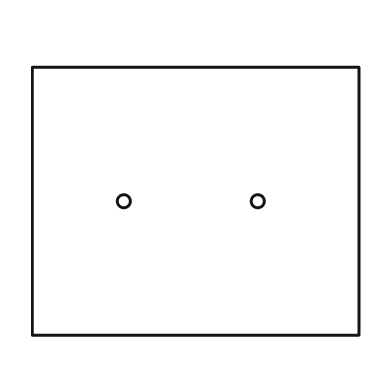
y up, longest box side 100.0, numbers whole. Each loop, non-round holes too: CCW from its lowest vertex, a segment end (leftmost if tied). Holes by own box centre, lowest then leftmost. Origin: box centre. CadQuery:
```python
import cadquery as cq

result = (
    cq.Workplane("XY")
    .moveTo(-50.0, -41.0)
    .lineTo(50.0, -41.0)
    .lineTo(50.0, 41.0)
    .lineTo(-50.0, 41.0)
    .close()
    .moveTo(-22.0, 0.0)
    .circle(2.0)
    .moveTo(19.0, 0.0)
    .circle(2.0)
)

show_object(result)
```